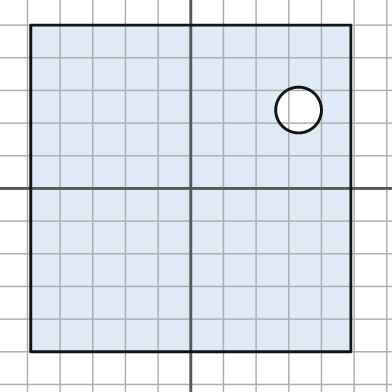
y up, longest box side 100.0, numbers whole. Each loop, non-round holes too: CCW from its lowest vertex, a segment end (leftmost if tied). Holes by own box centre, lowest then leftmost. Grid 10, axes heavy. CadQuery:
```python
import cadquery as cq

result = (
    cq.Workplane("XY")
    .moveTo(-49.0, -50.0)
    .lineTo(49.0, -50.0)
    .lineTo(49.0, 50.0)
    .lineTo(-49.0, 50.0)
    .close()
    .moveTo(33.0, 24.0)
    .circle(7.0)
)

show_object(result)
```